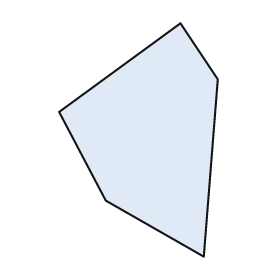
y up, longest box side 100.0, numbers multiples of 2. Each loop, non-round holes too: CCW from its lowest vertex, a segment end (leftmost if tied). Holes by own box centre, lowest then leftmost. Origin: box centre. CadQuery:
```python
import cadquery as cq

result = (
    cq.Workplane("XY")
    .moveTo(28.0, -50.0)
    .lineTo(34.0, 26.0)
    .lineTo(18.0, 50.0)
    .lineTo(-34.0, 12.0)
    .lineTo(-14.0, -26.0)
    .close()
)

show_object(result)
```